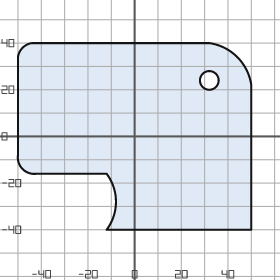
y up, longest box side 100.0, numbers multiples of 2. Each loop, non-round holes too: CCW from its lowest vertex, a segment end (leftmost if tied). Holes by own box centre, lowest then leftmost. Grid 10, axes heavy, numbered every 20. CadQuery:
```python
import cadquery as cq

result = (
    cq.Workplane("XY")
    .moveTo(-12.0, -40.0)
    .lineTo(50.0, -40.0)
    .lineTo(50.0, 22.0)
    .threePointArc((44.0, 34.0), (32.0, 40.0))
    .lineTo(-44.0, 40.0)
    .threePointArc((-48.0, 38.0), (-50.0, 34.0))
    .lineTo(-50.0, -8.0)
    .threePointArc((-48.0, -14.0), (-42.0, -16.0))
    .lineTo(-12.0, -16.0)
    .threePointArc((-8.0, -28.0), (-12.0, -40.0))
    .close()
    .moveTo(32.0, 24.0)
    .circle(4.0)
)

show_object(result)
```